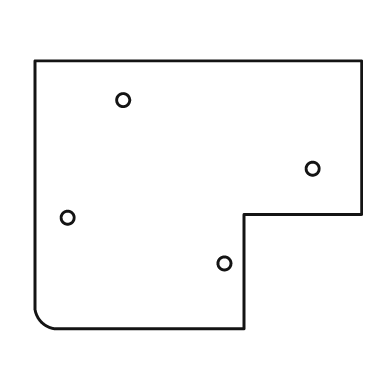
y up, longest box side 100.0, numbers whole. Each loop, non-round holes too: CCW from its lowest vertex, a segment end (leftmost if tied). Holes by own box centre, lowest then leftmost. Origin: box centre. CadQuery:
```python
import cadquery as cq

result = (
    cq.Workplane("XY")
    .moveTo(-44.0, -41.0)
    .lineTo(14.0, -41.0)
    .lineTo(14.0, -6.0)
    .lineTo(50.0, -6.0)
    .lineTo(50.0, 41.0)
    .lineTo(-50.0, 41.0)
    .lineTo(-50.0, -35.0)
    .threePointArc((-48.0, -39.0), (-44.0, -41.0))
    .close()
    .moveTo(8.0, -21.0)
    .circle(2.0)
    .moveTo(-40.0, -7.0)
    .circle(2.0)
    .moveTo(35.0, 8.0)
    .circle(2.0)
    .moveTo(-23.0, 29.0)
    .circle(2.0)
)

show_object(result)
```